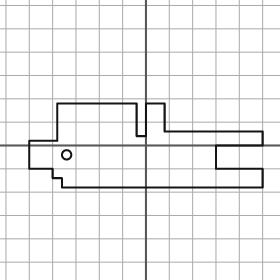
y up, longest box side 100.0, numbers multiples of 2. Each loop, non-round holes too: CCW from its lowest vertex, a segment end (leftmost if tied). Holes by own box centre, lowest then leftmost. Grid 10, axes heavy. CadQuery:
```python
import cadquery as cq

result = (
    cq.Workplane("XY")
    .moveTo(-36.0, -18.0)
    .lineTo(50.0, -18.0)
    .lineTo(50.0, -10.0)
    .lineTo(30.0, -10.0)
    .lineTo(30.0, 0.0)
    .lineTo(50.0, 0.0)
    .lineTo(50.0, 6.0)
    .lineTo(8.0, 6.0)
    .lineTo(8.0, 18.0)
    .lineTo(0.0, 18.0)
    .lineTo(0.0, 4.0)
    .lineTo(-4.0, 4.0)
    .lineTo(-4.0, 18.0)
    .lineTo(-38.0, 18.0)
    .lineTo(-38.0, 2.0)
    .lineTo(-50.0, 2.0)
    .lineTo(-50.0, -10.0)
    .lineTo(-40.0, -10.0)
    .lineTo(-40.0, -14.0)
    .lineTo(-36.0, -14.0)
    .close()
    .moveTo(-34.0, -4.0)
    .circle(2.0)
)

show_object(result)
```